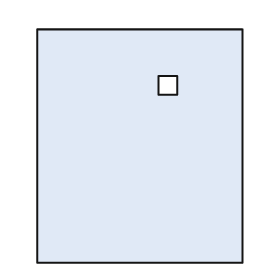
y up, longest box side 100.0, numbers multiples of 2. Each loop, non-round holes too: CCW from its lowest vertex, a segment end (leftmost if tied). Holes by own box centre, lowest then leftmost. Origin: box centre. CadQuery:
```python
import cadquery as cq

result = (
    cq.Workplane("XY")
    .moveTo(-44.0, -50.0)
    .lineTo(44.0, -50.0)
    .lineTo(44.0, 50.0)
    .lineTo(-44.0, 50.0)
    .close()
    .moveTo(8.0, 22.0)
    .lineTo(16.0, 22.0)
    .lineTo(16.0, 30.0)
    .lineTo(8.0, 30.0)
    .close()
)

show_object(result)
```